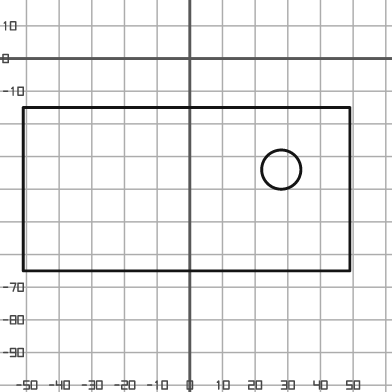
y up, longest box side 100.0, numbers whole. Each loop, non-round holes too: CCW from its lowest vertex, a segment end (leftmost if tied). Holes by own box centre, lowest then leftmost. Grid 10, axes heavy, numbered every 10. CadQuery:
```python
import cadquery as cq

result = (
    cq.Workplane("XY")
    .moveTo(-51.0, -65.0)
    .lineTo(49.0, -65.0)
    .lineTo(49.0, -15.0)
    .lineTo(-51.0, -15.0)
    .close()
    .moveTo(28.0, -34.0)
    .circle(6.0)
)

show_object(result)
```